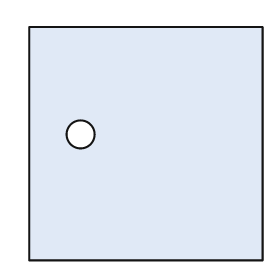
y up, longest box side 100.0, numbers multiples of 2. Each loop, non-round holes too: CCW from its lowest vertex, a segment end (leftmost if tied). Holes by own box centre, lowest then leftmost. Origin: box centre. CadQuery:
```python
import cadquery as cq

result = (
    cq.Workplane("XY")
    .moveTo(-50.0, -50.0)
    .lineTo(50.0, -50.0)
    .lineTo(50.0, 50.0)
    .lineTo(-50.0, 50.0)
    .close()
    .moveTo(-28.0, 4.0)
    .circle(6.0)
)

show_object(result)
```